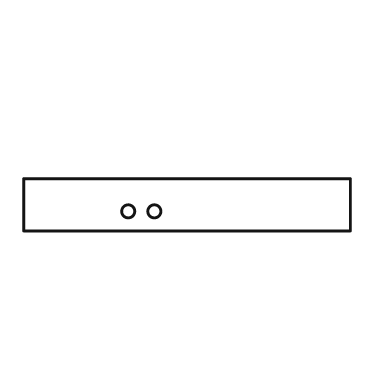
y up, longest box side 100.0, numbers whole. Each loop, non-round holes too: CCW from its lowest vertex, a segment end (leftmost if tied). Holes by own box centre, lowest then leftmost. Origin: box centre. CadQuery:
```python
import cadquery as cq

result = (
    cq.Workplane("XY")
    .moveTo(-50.0, -8.0)
    .lineTo(50.0, -8.0)
    .lineTo(50.0, 8.0)
    .lineTo(-50.0, 8.0)
    .close()
    .moveTo(-18.0, -2.0)
    .circle(2.0)
    .moveTo(-10.0, -2.0)
    .circle(2.0)
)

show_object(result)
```